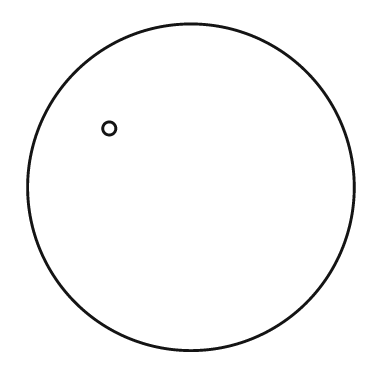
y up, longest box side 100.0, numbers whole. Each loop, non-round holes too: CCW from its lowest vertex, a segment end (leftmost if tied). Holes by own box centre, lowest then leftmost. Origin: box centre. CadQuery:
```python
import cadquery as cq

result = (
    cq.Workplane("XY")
    .moveTo(0.0, 0.0)
    .circle(50.0)
    .moveTo(-25.0, 18.0)
    .circle(2.0)
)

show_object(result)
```